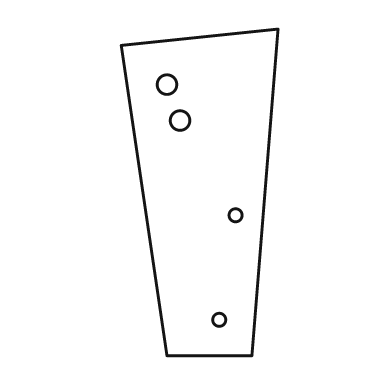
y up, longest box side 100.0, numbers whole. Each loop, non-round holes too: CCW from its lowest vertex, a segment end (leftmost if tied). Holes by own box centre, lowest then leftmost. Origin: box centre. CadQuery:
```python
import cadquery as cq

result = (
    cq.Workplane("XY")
    .moveTo(-10.0, -50.0)
    .lineTo(16.0, -50.0)
    .lineTo(24.0, 50.0)
    .lineTo(-24.0, 45.0)
    .close()
    .moveTo(6.0, -39.0)
    .circle(2.0)
    .moveTo(11.0, -7.0)
    .circle(2.0)
    .moveTo(-6.0, 22.0)
    .circle(3.0)
    .moveTo(-10.0, 33.0)
    .circle(3.0)
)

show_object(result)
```